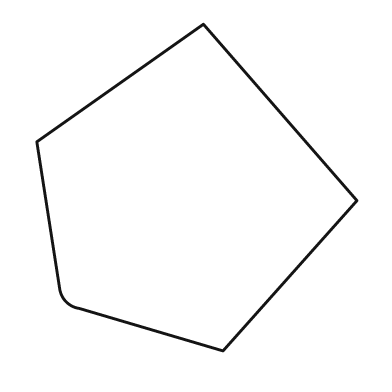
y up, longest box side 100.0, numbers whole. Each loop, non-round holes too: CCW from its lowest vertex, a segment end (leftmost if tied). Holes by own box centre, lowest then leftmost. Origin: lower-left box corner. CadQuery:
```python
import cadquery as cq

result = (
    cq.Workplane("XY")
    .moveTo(57.0, 0.0)
    .lineTo(98.0, 46.0)
    .lineTo(51.0, 100.0)
    .lineTo(0.0, 64.0)
    .lineTo(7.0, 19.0)
    .threePointArc((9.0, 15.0), (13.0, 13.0))
    .close()
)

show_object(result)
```